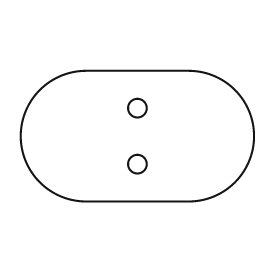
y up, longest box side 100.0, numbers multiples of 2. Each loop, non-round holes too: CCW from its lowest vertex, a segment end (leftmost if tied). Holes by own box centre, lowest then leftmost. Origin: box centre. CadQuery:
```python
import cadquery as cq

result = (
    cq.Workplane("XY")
    .moveTo(-22.0, -28.0)
    .lineTo(22.0, -28.0)
    .threePointArc((50.0, 0.0), (22.0, 28.0))
    .lineTo(-22.0, 28.0)
    .threePointArc((-50.0, 0.0), (-22.0, -28.0))
    .close()
    .moveTo(0.0, -12.0)
    .circle(4.0)
    .moveTo(0.0, 12.0)
    .circle(4.0)
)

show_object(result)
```